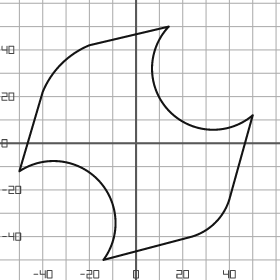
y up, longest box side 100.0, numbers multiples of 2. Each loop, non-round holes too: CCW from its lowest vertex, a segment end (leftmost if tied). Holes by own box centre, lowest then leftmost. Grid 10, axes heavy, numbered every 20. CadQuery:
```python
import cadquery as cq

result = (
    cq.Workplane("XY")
    .moveTo(-14.0, -50.0)
    .lineTo(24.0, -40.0)
    .threePointArc((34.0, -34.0), (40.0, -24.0))
    .lineTo(50.0, 12.0)
    .threePointArc((14.0, 14.0), (14.0, 50.0))
    .lineTo(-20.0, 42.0)
    .threePointArc((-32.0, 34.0), (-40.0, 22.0))
    .lineTo(-50.0, -12.0)
    .threePointArc((-16.0, -16.0), (-14.0, -50.0))
    .close()
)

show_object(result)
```